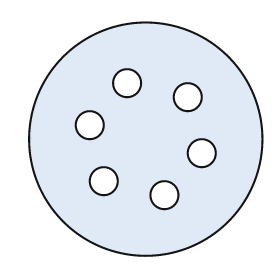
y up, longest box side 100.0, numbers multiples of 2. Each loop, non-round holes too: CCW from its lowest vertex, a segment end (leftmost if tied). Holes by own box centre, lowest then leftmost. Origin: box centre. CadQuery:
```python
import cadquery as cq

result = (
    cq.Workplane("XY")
    .moveTo(0.0, 0.0)
    .circle(50.0)
    .moveTo(8.0, -24.0)
    .circle(6.0)
    .moveTo(-18.0, -18.0)
    .circle(6.0)
    .moveTo(24.0, -6.0)
    .circle(6.0)
    .moveTo(-24.0, 6.0)
    .circle(6.0)
    .moveTo(18.0, 18.0)
    .circle(6.0)
    .moveTo(-8.0, 24.0)
    .circle(6.0)
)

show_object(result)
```